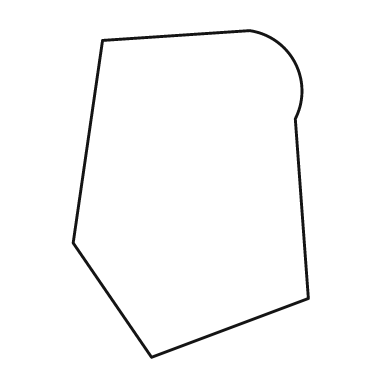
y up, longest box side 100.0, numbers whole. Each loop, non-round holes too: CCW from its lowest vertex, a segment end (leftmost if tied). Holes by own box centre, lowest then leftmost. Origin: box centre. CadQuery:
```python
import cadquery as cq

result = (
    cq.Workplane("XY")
    .moveTo(-12.0, -50.0)
    .lineTo(36.0, -32.0)
    .lineTo(32.0, 23.0)
    .threePointArc((32.0, 40.0), (18.0, 50.0))
    .lineTo(-27.0, 47.0)
    .lineTo(-36.0, -15.0)
    .close()
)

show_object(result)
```